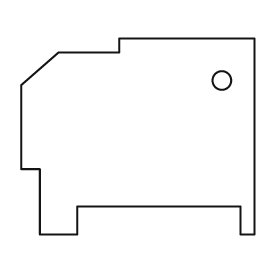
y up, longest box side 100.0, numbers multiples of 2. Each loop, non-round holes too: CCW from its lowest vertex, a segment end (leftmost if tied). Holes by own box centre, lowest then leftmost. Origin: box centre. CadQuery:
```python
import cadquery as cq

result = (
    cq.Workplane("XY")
    .moveTo(-42.0, -42.0)
    .lineTo(-26.0, -42.0)
    .lineTo(-26.0, -30.0)
    .lineTo(44.0, -30.0)
    .lineTo(44.0, -42.0)
    .lineTo(50.0, -42.0)
    .lineTo(50.0, 42.0)
    .lineTo(-8.0, 42.0)
    .lineTo(-8.0, 36.0)
    .lineTo(-34.0, 36.0)
    .lineTo(-50.0, 22.0)
    .lineTo(-50.0, -14.0)
    .lineTo(-42.0, -14.0)
    .close()
    .moveTo(36.0, 24.0)
    .circle(4.0)
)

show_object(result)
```